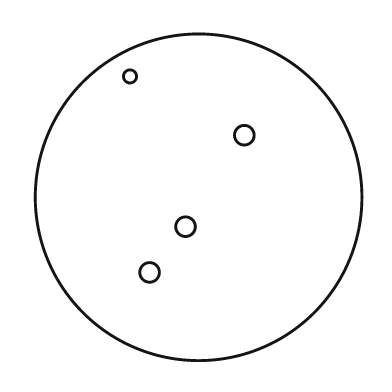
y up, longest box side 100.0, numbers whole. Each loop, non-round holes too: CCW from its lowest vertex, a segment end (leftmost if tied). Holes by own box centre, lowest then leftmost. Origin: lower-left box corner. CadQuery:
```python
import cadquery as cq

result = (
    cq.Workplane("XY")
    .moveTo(50.0, 50.0)
    .circle(50.0)
    .moveTo(35.0, 27.0)
    .circle(3.0)
    .moveTo(46.0, 41.0)
    .circle(3.0)
    .moveTo(64.0, 69.0)
    .circle(3.0)
    .moveTo(29.0, 87.0)
    .circle(2.0)
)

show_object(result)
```